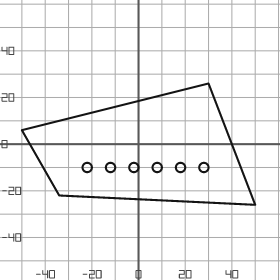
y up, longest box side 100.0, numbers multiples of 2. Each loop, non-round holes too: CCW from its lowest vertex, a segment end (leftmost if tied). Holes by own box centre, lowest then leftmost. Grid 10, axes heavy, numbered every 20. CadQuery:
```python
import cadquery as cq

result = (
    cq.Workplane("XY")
    .moveTo(50.0, -26.0)
    .lineTo(30.0, 26.0)
    .lineTo(-50.0, 6.0)
    .lineTo(-34.0, -22.0)
    .close()
    .moveTo(-22.0, -10.0)
    .circle(2.0)
    .moveTo(-12.0, -10.0)
    .circle(2.0)
    .moveTo(-2.0, -10.0)
    .circle(2.0)
    .moveTo(8.0, -10.0)
    .circle(2.0)
    .moveTo(18.0, -10.0)
    .circle(2.0)
    .moveTo(28.0, -10.0)
    .circle(2.0)
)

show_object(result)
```